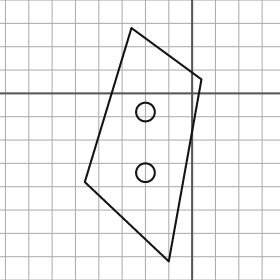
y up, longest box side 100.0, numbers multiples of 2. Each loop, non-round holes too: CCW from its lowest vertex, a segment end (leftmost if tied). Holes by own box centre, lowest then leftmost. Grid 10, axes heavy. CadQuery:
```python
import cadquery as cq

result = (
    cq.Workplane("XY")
    .moveTo(-10.0, -72.0)
    .lineTo(4.0, 6.0)
    .lineTo(-26.0, 28.0)
    .lineTo(-46.0, -38.0)
    .close()
    .moveTo(-20.0, -34.0)
    .circle(4.0)
    .moveTo(-20.0, -8.0)
    .circle(4.0)
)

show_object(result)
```